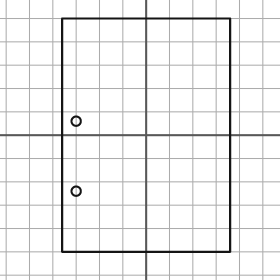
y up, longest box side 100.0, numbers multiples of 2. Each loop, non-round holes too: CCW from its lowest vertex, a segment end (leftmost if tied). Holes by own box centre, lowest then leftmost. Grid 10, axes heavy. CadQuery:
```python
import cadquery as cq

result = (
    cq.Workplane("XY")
    .moveTo(-36.0, -50.0)
    .lineTo(36.0, -50.0)
    .lineTo(36.0, 50.0)
    .lineTo(-36.0, 50.0)
    .close()
    .moveTo(-30.0, -24.0)
    .circle(2.0)
    .moveTo(-30.0, 6.0)
    .circle(2.0)
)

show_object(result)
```